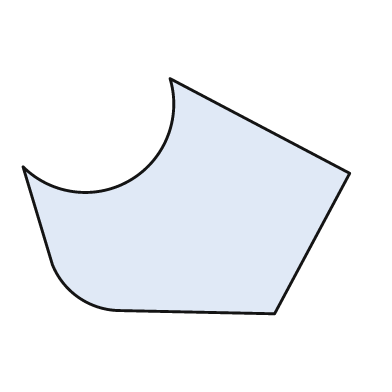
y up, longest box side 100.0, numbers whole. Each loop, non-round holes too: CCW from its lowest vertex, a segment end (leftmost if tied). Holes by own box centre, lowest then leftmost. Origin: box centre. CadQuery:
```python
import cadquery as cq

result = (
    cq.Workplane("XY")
    .moveTo(27.0, -36.0)
    .lineTo(50.0, 7.0)
    .lineTo(-5.0, 36.0)
    .threePointArc((-17.0, 5.0), (-50.0, 9.0))
    .lineTo(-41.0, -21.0)
    .threePointArc((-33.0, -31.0), (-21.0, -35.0))
    .close()
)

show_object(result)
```